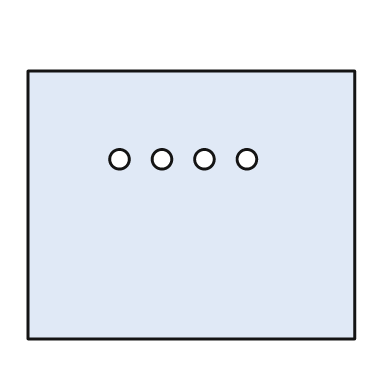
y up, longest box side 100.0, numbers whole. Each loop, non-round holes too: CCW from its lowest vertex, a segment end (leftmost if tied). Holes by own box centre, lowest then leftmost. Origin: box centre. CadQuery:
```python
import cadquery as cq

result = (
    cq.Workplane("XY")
    .moveTo(-50.0, -41.0)
    .lineTo(50.0, -41.0)
    .lineTo(50.0, 41.0)
    .lineTo(-50.0, 41.0)
    .close()
    .moveTo(-22.0, 14.0)
    .circle(3.0)
    .moveTo(-9.0, 14.0)
    .circle(3.0)
    .moveTo(4.0, 14.0)
    .circle(3.0)
    .moveTo(17.0, 14.0)
    .circle(3.0)
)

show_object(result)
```